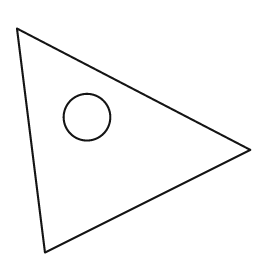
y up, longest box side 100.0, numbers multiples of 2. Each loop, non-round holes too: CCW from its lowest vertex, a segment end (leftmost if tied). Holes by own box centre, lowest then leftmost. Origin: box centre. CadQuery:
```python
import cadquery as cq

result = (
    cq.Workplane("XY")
    .moveTo(-38.0, -48.0)
    .lineTo(50.0, -4.0)
    .lineTo(-50.0, 48.0)
    .close()
    .moveTo(-20.0, 10.0)
    .circle(10.0)
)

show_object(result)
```